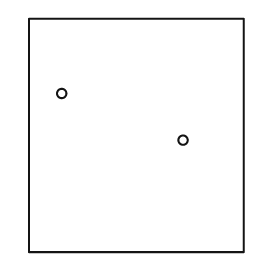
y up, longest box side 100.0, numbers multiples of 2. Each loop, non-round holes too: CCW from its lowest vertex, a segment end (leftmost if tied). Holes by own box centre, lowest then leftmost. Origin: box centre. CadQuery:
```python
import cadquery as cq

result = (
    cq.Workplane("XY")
    .moveTo(-46.0, -50.0)
    .lineTo(46.0, -50.0)
    .lineTo(46.0, 50.0)
    .lineTo(-46.0, 50.0)
    .close()
    .moveTo(20.0, -2.0)
    .circle(2.0)
    .moveTo(-32.0, 18.0)
    .circle(2.0)
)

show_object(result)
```